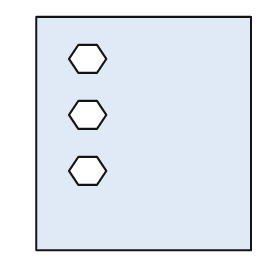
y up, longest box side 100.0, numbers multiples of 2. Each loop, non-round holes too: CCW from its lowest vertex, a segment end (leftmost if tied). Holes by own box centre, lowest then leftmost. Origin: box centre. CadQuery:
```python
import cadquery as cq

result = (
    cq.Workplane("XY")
    .moveTo(-46.0, -50.0)
    .lineTo(46.0, -50.0)
    .lineTo(46.0, 50.0)
    .lineTo(-46.0, 50.0)
    .close()
    .moveTo(-28.0, -22.0)
    .lineTo(-20.0, -22.0)
    .lineTo(-16.0, -16.0)
    .lineTo(-20.0, -10.0)
    .lineTo(-28.0, -10.0)
    .lineTo(-32.0, -16.0)
    .close()
    .moveTo(-28.0, 2.0)
    .lineTo(-20.0, 2.0)
    .lineTo(-16.0, 8.0)
    .lineTo(-20.0, 14.0)
    .lineTo(-28.0, 14.0)
    .lineTo(-32.0, 8.0)
    .close()
    .moveTo(-28.0, 26.0)
    .lineTo(-20.0, 26.0)
    .lineTo(-16.0, 32.0)
    .lineTo(-20.0, 38.0)
    .lineTo(-28.0, 38.0)
    .lineTo(-32.0, 32.0)
    .close()
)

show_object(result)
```